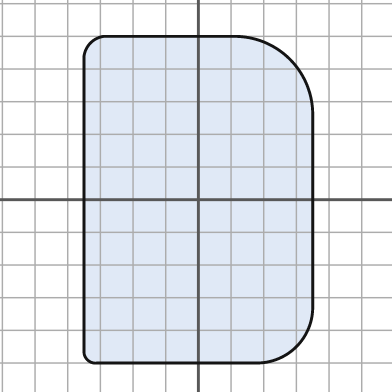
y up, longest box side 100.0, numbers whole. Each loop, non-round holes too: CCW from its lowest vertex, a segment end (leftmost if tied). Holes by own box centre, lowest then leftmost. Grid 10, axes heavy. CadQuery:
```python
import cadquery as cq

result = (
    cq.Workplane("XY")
    .moveTo(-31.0, -50.0)
    .lineTo(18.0, -50.0)
    .threePointArc((30.0, -45.0), (35.0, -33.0))
    .lineTo(35.0, 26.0)
    .threePointArc((28.0, 43.0), (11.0, 50.0))
    .lineTo(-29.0, 50.0)
    .threePointArc((-33.0, 48.0), (-35.0, 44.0))
    .lineTo(-35.0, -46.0)
    .threePointArc((-34.0, -49.0), (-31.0, -50.0))
    .close()
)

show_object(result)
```